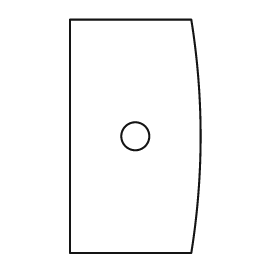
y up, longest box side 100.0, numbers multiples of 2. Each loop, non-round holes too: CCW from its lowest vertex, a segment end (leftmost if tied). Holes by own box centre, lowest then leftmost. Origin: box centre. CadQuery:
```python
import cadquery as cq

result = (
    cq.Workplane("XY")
    .moveTo(-28.0, -50.0)
    .lineTo(24.0, -50.0)
    .threePointArc((28.0, 0.0), (24.0, 50.0))
    .lineTo(-28.0, 50.0)
    .close()
    .moveTo(0.0, 0.0)
    .circle(6.0)
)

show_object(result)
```